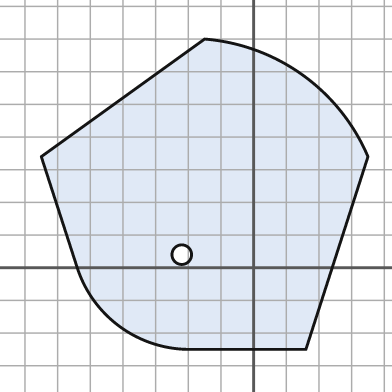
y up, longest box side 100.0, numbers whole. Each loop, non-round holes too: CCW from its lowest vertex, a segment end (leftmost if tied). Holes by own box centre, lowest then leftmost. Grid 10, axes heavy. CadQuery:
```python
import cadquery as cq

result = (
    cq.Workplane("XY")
    .moveTo(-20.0, -25.0)
    .lineTo(16.0, -25.0)
    .lineTo(35.0, 34.0)
    .threePointArc((15.0, 59.0), (-15.0, 70.0))
    .lineTo(-65.0, 34.0)
    .lineTo(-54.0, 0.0)
    .threePointArc((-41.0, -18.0), (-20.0, -25.0))
    .close()
    .moveTo(-22.0, 4.0)
    .circle(3.0)
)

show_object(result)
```